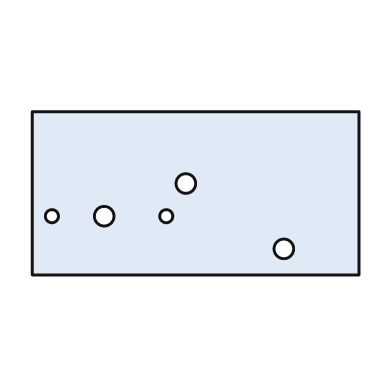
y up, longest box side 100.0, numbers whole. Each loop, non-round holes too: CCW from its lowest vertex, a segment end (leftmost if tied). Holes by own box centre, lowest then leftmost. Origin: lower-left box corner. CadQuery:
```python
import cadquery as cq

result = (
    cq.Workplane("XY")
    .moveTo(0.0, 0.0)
    .lineTo(100.0, 0.0)
    .lineTo(100.0, 50.0)
    .lineTo(0.0, 50.0)
    .close()
    .moveTo(77.0, 8.0)
    .circle(3.0)
    .moveTo(6.0, 18.0)
    .circle(2.0)
    .moveTo(22.0, 18.0)
    .circle(3.0)
    .moveTo(41.0, 18.0)
    .circle(2.0)
    .moveTo(47.0, 28.0)
    .circle(3.0)
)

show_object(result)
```